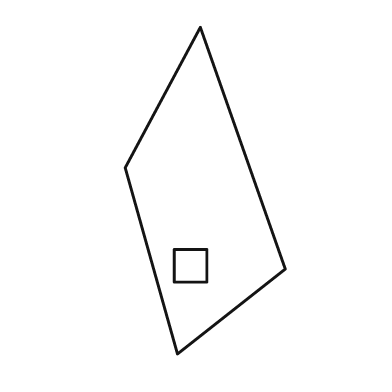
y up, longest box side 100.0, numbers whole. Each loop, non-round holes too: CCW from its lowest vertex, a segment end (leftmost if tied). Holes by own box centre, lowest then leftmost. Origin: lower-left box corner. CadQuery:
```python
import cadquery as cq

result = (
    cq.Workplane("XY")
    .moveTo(16.0, 0.0)
    .lineTo(49.0, 26.0)
    .lineTo(23.0, 100.0)
    .lineTo(0.0, 57.0)
    .close()
    .moveTo(15.0, 22.0)
    .lineTo(25.0, 22.0)
    .lineTo(25.0, 32.0)
    .lineTo(15.0, 32.0)
    .close()
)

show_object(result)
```